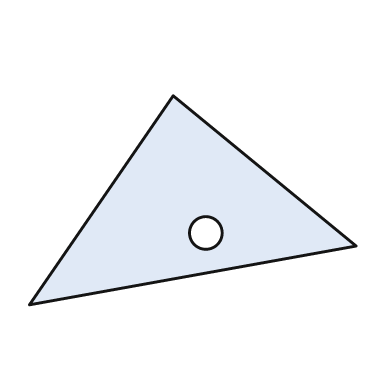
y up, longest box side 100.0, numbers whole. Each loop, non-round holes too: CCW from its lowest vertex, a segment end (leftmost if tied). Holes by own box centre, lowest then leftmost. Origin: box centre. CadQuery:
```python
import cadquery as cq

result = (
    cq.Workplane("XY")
    .moveTo(-50.0, -32.0)
    .lineTo(50.0, -14.0)
    .lineTo(-6.0, 32.0)
    .close()
    .moveTo(4.0, -10.0)
    .circle(5.0)
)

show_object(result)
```